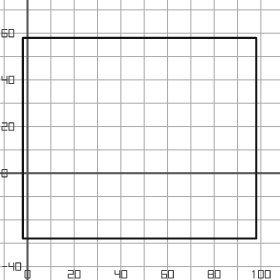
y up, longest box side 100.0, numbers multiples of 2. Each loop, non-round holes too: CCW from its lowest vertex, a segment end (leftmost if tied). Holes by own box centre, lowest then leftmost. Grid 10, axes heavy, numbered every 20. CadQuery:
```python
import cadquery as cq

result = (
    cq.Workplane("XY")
    .moveTo(-2.0, -28.0)
    .lineTo(98.0, -28.0)
    .lineTo(98.0, 58.0)
    .lineTo(-2.0, 58.0)
    .close()
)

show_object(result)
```